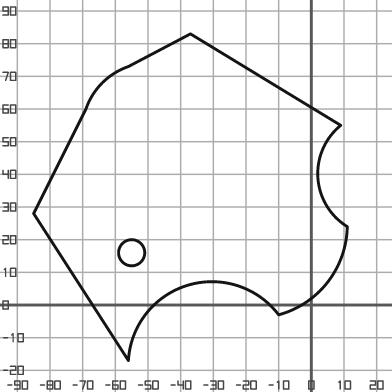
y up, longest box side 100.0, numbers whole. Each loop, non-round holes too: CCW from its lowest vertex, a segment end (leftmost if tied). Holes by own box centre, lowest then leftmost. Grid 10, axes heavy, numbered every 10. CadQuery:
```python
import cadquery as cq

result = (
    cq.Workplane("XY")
    .moveTo(-56.0, -17.0)
    .threePointArc((-38.0, 6.0), (-10.0, -3.0))
    .threePointArc((5.0, 7.0), (11.0, 24.0))
    .threePointArc((2.0, 39.0), (9.0, 55.0))
    .lineTo(-37.0, 83.0)
    .lineTo(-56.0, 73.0)
    .threePointArc((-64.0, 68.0), (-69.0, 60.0))
    .lineTo(-85.0, 28.0)
    .close()
    .moveTo(-55.0, 16.0)
    .circle(4.0)
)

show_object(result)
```